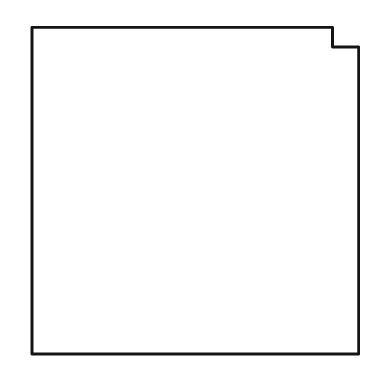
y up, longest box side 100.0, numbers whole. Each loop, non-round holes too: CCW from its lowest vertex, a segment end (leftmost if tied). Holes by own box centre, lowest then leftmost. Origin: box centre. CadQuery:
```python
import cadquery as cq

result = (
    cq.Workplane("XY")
    .moveTo(-50.0, -50.0)
    .lineTo(50.0, -50.0)
    .lineTo(50.0, 44.0)
    .lineTo(42.0, 44.0)
    .lineTo(42.0, 50.0)
    .lineTo(-50.0, 50.0)
    .close()
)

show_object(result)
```